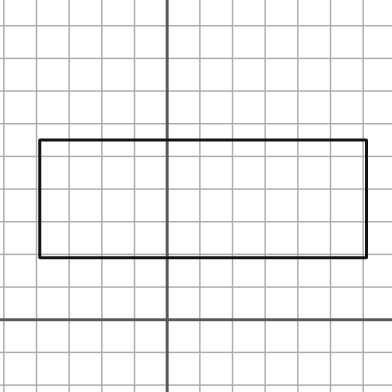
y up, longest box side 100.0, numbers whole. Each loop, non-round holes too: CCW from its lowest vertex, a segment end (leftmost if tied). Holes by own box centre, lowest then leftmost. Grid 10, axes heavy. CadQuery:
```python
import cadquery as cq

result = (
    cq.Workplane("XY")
    .moveTo(-39.0, 19.0)
    .lineTo(61.0, 19.0)
    .lineTo(61.0, 55.0)
    .lineTo(-39.0, 55.0)
    .close()
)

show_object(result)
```